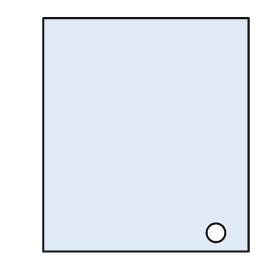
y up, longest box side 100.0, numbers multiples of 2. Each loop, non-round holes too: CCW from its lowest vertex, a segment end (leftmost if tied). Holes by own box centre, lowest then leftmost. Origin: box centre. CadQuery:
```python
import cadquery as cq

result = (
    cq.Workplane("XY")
    .moveTo(-44.0, -50.0)
    .lineTo(44.0, -50.0)
    .lineTo(44.0, 50.0)
    .lineTo(-44.0, 50.0)
    .close()
    .moveTo(30.0, -42.0)
    .circle(4.0)
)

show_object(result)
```